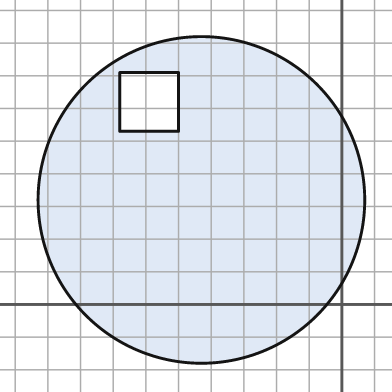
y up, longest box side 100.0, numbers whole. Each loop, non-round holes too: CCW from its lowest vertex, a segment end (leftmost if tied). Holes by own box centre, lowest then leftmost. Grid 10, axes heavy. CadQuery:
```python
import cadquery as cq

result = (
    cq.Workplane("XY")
    .moveTo(-43.0, 32.0)
    .circle(50.0)
    .moveTo(-68.0, 53.0)
    .lineTo(-50.0, 53.0)
    .lineTo(-50.0, 71.0)
    .lineTo(-68.0, 71.0)
    .close()
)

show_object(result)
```